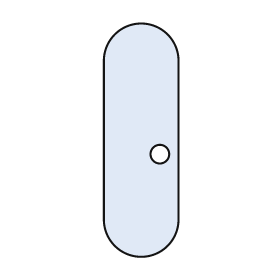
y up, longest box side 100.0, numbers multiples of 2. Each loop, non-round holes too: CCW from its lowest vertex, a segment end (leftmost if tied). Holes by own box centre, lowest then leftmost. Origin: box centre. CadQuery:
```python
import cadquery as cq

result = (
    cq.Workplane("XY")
    .moveTo(-16.0, -34.0)
    .threePointArc((0.0, -50.0), (16.0, -34.0))
    .lineTo(16.0, 34.0)
    .threePointArc((0.0, 50.0), (-16.0, 34.0))
    .close()
    .moveTo(8.0, -6.0)
    .circle(4.0)
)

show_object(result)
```